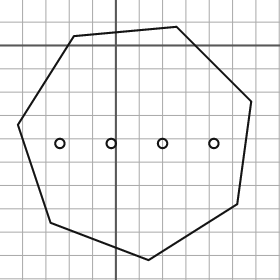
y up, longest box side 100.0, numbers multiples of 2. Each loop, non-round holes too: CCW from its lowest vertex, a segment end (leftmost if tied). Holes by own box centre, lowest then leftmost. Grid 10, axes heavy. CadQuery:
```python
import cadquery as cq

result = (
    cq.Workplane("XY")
    .moveTo(14.0, -92.0)
    .lineTo(52.0, -68.0)
    .lineTo(58.0, -24.0)
    .lineTo(26.0, 8.0)
    .lineTo(-18.0, 4.0)
    .lineTo(-42.0, -34.0)
    .lineTo(-28.0, -76.0)
    .close()
    .moveTo(-24.0, -42.0)
    .circle(2.0)
    .moveTo(-2.0, -42.0)
    .circle(2.0)
    .moveTo(20.0, -42.0)
    .circle(2.0)
    .moveTo(42.0, -42.0)
    .circle(2.0)
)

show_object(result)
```